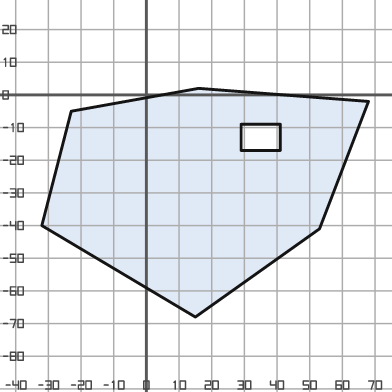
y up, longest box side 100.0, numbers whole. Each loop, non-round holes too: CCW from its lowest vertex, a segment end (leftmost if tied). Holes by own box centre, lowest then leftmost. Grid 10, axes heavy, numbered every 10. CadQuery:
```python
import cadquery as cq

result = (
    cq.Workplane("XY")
    .moveTo(15.0, -68.0)
    .lineTo(53.0, -41.0)
    .lineTo(68.0, -2.0)
    .lineTo(16.0, 2.0)
    .lineTo(-23.0, -5.0)
    .lineTo(-32.0, -40.0)
    .close()
    .moveTo(29.0, -17.0)
    .lineTo(41.0, -17.0)
    .lineTo(41.0, -9.0)
    .lineTo(29.0, -9.0)
    .close()
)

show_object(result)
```